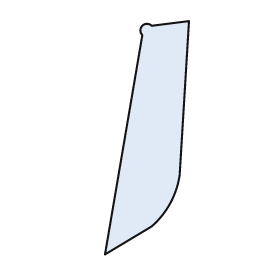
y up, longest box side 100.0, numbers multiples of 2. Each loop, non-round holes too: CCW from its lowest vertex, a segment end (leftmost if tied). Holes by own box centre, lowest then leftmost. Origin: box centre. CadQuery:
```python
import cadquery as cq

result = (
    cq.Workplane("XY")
    .moveTo(-18.0, -50.0)
    .lineTo(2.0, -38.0)
    .threePointArc((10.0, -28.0), (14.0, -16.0))
    .lineTo(18.0, 50.0)
    .lineTo(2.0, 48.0)
    .threePointArc((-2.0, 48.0), (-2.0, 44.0))
    .close()
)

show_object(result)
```